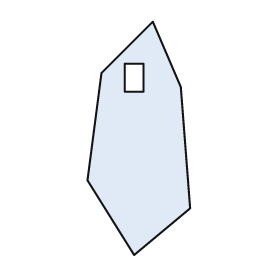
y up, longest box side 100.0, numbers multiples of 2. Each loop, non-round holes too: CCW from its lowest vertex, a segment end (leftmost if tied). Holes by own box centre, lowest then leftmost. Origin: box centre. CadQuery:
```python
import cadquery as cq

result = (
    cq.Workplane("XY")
    .moveTo(-2.0, -50.0)
    .lineTo(22.0, -30.0)
    .lineTo(18.0, 22.0)
    .lineTo(6.0, 50.0)
    .lineTo(-16.0, 28.0)
    .lineTo(-22.0, -18.0)
    .close()
    .moveTo(-6.0, 20.0)
    .lineTo(2.0, 20.0)
    .lineTo(2.0, 32.0)
    .lineTo(-6.0, 32.0)
    .close()
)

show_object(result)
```